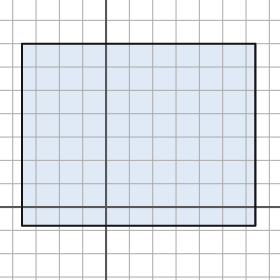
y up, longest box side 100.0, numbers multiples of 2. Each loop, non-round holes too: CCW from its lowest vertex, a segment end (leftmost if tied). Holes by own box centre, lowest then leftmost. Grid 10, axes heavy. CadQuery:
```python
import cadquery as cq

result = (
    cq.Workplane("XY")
    .moveTo(-36.0, -8.0)
    .lineTo(64.0, -8.0)
    .lineTo(64.0, 70.0)
    .lineTo(-36.0, 70.0)
    .close()
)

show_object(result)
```